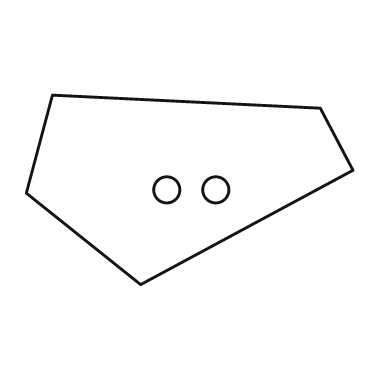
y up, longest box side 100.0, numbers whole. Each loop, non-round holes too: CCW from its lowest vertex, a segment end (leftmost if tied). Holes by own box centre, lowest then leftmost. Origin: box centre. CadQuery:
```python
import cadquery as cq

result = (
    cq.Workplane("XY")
    .moveTo(-15.0, -29.0)
    .lineTo(50.0, 6.0)
    .lineTo(40.0, 25.0)
    .lineTo(-42.0, 29.0)
    .lineTo(-50.0, -1.0)
    .close()
    .moveTo(-7.0, 0.0)
    .circle(4.0)
    .moveTo(8.0, 0.0)
    .circle(4.0)
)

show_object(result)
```